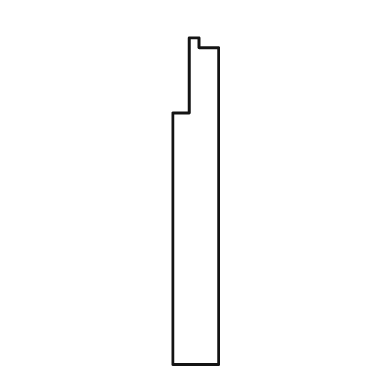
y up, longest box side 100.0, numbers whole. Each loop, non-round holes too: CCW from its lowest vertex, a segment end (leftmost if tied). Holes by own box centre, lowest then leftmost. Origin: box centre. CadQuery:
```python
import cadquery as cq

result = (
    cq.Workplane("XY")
    .moveTo(-7.0, -50.0)
    .lineTo(7.0, -50.0)
    .lineTo(7.0, 47.0)
    .lineTo(1.0, 47.0)
    .lineTo(1.0, 50.0)
    .lineTo(-2.0, 50.0)
    .lineTo(-2.0, 27.0)
    .lineTo(-7.0, 27.0)
    .close()
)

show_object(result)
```